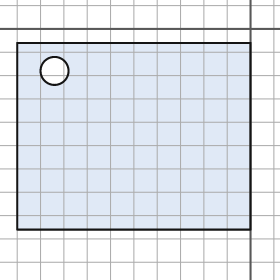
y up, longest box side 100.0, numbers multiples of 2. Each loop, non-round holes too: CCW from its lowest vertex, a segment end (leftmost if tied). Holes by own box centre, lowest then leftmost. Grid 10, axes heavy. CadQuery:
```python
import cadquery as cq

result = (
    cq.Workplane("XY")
    .moveTo(-100.0, -86.0)
    .lineTo(0.0, -86.0)
    .lineTo(0.0, -6.0)
    .lineTo(-100.0, -6.0)
    .close()
    .moveTo(-84.0, -18.0)
    .circle(6.0)
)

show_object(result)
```